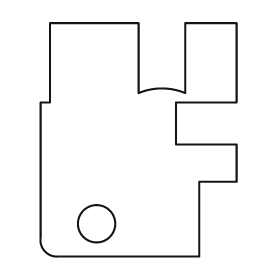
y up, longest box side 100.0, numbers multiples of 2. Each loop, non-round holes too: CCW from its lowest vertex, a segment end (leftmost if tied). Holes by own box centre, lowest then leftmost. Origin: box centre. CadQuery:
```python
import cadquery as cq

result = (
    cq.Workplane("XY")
    .moveTo(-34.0, -50.0)
    .lineTo(26.0, -50.0)
    .lineTo(26.0, -18.0)
    .lineTo(42.0, -18.0)
    .lineTo(42.0, -2.0)
    .lineTo(16.0, -2.0)
    .lineTo(16.0, 16.0)
    .lineTo(42.0, 16.0)
    .lineTo(42.0, 50.0)
    .lineTo(20.0, 50.0)
    .lineTo(20.0, 20.0)
    .threePointArc((10.0, 22.0), (0.0, 20.0))
    .lineTo(0.0, 50.0)
    .lineTo(-38.0, 50.0)
    .lineTo(-38.0, 16.0)
    .lineTo(-42.0, 16.0)
    .lineTo(-42.0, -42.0)
    .threePointArc((-40.0, -48.0), (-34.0, -50.0))
    .close()
    .moveTo(-18.0, -36.0)
    .circle(8.0)
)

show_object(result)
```